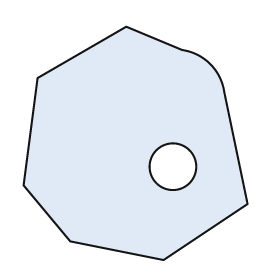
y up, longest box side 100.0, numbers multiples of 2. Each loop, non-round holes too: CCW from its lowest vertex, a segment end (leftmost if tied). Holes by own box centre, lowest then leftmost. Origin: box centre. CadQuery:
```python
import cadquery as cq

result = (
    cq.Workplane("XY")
    .moveTo(12.0, -50.0)
    .lineTo(48.0, -26.0)
    .lineTo(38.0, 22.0)
    .threePointArc((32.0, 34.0), (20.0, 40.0))
    .lineTo(-4.0, 50.0)
    .lineTo(-42.0, 28.0)
    .lineTo(-48.0, -18.0)
    .lineTo(-28.0, -42.0)
    .close()
    .moveTo(16.0, -10.0)
    .circle(10.0)
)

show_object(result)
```